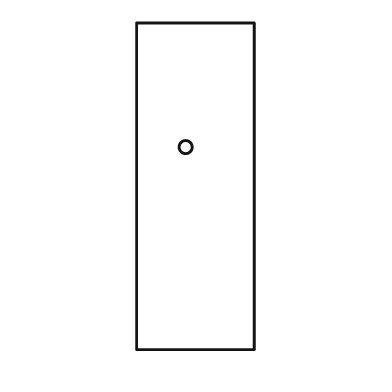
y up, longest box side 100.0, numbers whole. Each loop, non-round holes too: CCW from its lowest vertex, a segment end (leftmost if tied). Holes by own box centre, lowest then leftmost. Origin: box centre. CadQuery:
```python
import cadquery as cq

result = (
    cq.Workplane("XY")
    .moveTo(-18.0, -50.0)
    .lineTo(18.0, -50.0)
    .lineTo(18.0, 50.0)
    .lineTo(-18.0, 50.0)
    .close()
    .moveTo(-3.0, 12.0)
    .circle(2.0)
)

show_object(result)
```